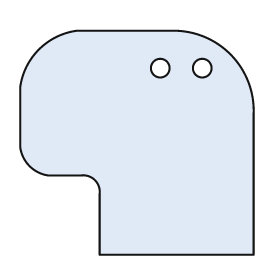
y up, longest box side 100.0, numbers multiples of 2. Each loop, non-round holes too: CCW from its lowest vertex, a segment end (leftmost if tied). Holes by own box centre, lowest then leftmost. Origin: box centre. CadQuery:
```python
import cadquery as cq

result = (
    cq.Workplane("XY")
    .moveTo(-16.0, -48.0)
    .lineTo(50.0, -48.0)
    .lineTo(50.0, 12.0)
    .threePointArc((40.0, 38.0), (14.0, 48.0))
    .lineTo(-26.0, 48.0)
    .threePointArc((-42.0, 40.0), (-50.0, 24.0))
    .lineTo(-50.0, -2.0)
    .threePointArc((-46.0, -10.0), (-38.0, -14.0))
    .lineTo(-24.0, -14.0)
    .threePointArc((-18.0, -16.0), (-16.0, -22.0))
    .close()
    .moveTo(10.0, 32.0)
    .circle(4.0)
    .moveTo(28.0, 32.0)
    .circle(4.0)
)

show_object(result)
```